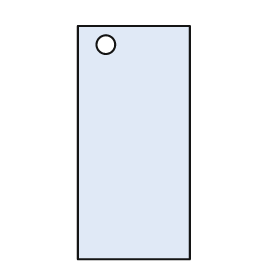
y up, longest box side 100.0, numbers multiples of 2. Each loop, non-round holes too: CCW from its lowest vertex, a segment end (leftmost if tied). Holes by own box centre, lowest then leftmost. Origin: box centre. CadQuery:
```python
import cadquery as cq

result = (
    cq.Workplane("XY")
    .moveTo(-24.0, -50.0)
    .lineTo(24.0, -50.0)
    .lineTo(24.0, 50.0)
    .lineTo(-24.0, 50.0)
    .close()
    .moveTo(-12.0, 42.0)
    .circle(4.0)
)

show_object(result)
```